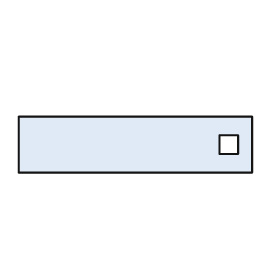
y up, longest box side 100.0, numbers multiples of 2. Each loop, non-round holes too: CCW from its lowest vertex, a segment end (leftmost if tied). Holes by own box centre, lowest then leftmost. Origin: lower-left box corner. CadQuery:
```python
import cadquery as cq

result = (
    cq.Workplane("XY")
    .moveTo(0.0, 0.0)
    .lineTo(100.0, 0.0)
    .lineTo(100.0, 24.0)
    .lineTo(0.0, 24.0)
    .close()
    .moveTo(86.0, 8.0)
    .lineTo(94.0, 8.0)
    .lineTo(94.0, 16.0)
    .lineTo(86.0, 16.0)
    .close()
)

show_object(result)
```